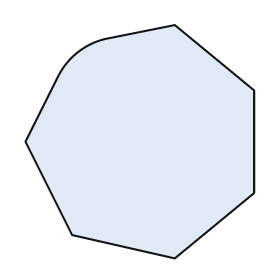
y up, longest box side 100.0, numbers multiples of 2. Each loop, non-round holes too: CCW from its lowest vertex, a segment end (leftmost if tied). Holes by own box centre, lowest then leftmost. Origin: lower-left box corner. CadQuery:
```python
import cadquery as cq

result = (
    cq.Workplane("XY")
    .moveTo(64.0, 0.0)
    .lineTo(98.0, 28.0)
    .lineTo(98.0, 72.0)
    .lineTo(64.0, 100.0)
    .lineTo(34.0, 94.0)
    .threePointArc((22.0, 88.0), (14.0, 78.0))
    .lineTo(0.0, 50.0)
    .lineTo(20.0, 10.0)
    .close()
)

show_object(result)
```